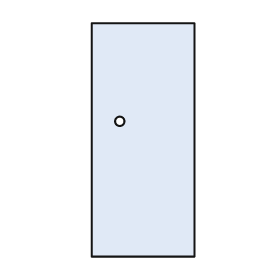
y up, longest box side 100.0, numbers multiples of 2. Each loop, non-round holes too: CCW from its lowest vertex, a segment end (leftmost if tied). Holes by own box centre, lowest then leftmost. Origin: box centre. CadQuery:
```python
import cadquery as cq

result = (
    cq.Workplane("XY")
    .moveTo(-22.0, -50.0)
    .lineTo(22.0, -50.0)
    .lineTo(22.0, 50.0)
    .lineTo(-22.0, 50.0)
    .close()
    .moveTo(-10.0, 8.0)
    .circle(2.0)
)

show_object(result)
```